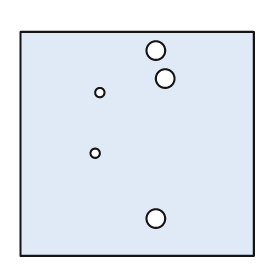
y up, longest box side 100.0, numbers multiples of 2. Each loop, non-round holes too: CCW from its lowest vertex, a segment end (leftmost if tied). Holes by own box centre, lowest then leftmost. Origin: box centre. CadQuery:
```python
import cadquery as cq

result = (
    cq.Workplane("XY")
    .moveTo(-50.0, -48.0)
    .lineTo(50.0, -48.0)
    .lineTo(50.0, 48.0)
    .lineTo(-50.0, 48.0)
    .close()
    .moveTo(8.0, -32.0)
    .circle(4.0)
    .moveTo(-18.0, -4.0)
    .circle(2.0)
    .moveTo(-16.0, 22.0)
    .circle(2.0)
    .moveTo(12.0, 28.0)
    .circle(4.0)
    .moveTo(8.0, 40.0)
    .circle(4.0)
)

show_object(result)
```